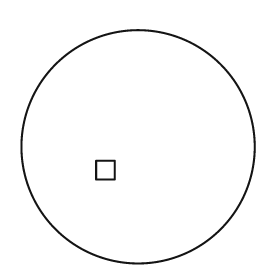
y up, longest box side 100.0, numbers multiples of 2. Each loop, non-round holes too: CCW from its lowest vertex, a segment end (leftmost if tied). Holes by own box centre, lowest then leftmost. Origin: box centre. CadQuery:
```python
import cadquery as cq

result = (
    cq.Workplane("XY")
    .moveTo(0.0, 0.0)
    .circle(50.0)
    .moveTo(-18.0, -14.0)
    .lineTo(-10.0, -14.0)
    .lineTo(-10.0, -6.0)
    .lineTo(-18.0, -6.0)
    .close()
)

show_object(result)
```